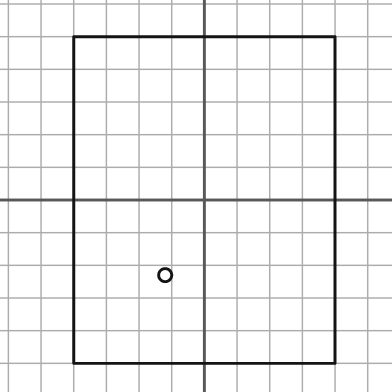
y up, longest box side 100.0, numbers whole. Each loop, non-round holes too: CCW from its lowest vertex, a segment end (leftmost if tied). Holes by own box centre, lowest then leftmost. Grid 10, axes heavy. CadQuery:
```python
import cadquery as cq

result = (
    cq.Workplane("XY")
    .moveTo(-40.0, -50.0)
    .lineTo(40.0, -50.0)
    .lineTo(40.0, 50.0)
    .lineTo(-40.0, 50.0)
    .close()
    .moveTo(-12.0, -23.0)
    .circle(2.0)
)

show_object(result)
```